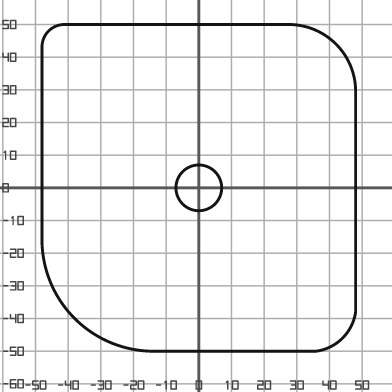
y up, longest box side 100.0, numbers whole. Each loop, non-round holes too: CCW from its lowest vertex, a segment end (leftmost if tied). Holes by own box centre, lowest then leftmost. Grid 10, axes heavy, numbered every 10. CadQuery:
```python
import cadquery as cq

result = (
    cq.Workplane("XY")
    .moveTo(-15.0, -50.0)
    .lineTo(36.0, -50.0)
    .threePointArc((44.0, -46.0), (48.0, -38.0))
    .lineTo(48.0, 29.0)
    .threePointArc((42.0, 44.0), (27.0, 50.0))
    .lineTo(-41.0, 50.0)
    .threePointArc((-46.0, 48.0), (-48.0, 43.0))
    .lineTo(-48.0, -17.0)
    .threePointArc((-38.0, -40.0), (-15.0, -50.0))
    .close()
    .moveTo(0.0, 0.0)
    .circle(7.0)
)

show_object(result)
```